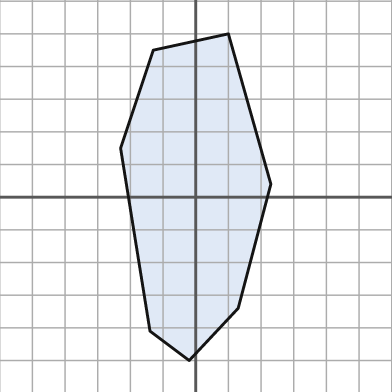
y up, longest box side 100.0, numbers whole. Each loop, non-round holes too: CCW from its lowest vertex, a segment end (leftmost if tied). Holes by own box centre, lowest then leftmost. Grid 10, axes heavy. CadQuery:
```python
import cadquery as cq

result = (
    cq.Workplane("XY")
    .moveTo(-2.0, -50.0)
    .lineTo(13.0, -34.0)
    .lineTo(23.0, 4.0)
    .lineTo(10.0, 50.0)
    .lineTo(-13.0, 45.0)
    .lineTo(-23.0, 15.0)
    .lineTo(-14.0, -41.0)
    .close()
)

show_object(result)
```